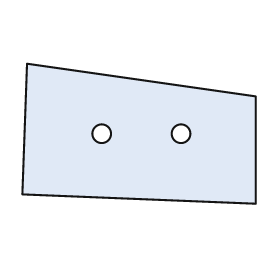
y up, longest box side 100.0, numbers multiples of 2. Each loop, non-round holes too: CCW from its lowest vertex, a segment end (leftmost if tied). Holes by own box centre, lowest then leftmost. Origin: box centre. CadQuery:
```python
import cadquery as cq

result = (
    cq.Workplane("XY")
    .moveTo(50.0, -30.0)
    .lineTo(50.0, 16.0)
    .lineTo(-48.0, 30.0)
    .lineTo(-50.0, -26.0)
    .close()
    .moveTo(-16.0, 0.0)
    .circle(4.0)
    .moveTo(18.0, 0.0)
    .circle(4.0)
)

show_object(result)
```